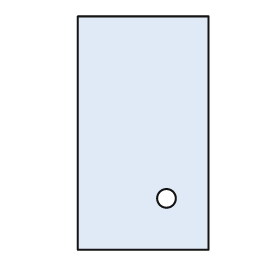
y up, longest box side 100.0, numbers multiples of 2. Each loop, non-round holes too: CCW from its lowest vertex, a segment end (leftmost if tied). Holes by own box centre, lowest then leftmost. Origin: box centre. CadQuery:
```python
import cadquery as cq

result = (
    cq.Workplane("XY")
    .moveTo(-28.0, -50.0)
    .lineTo(28.0, -50.0)
    .lineTo(28.0, 50.0)
    .lineTo(-28.0, 50.0)
    .close()
    .moveTo(10.0, -28.0)
    .circle(4.0)
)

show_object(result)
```